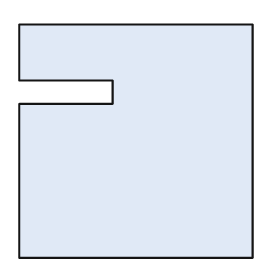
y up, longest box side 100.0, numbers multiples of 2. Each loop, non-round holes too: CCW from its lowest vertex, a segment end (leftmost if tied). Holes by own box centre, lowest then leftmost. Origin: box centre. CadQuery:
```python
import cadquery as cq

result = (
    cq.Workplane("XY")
    .moveTo(-50.0, -50.0)
    .lineTo(50.0, -50.0)
    .lineTo(50.0, 50.0)
    .lineTo(-50.0, 50.0)
    .lineTo(-50.0, 26.0)
    .lineTo(-10.0, 26.0)
    .lineTo(-10.0, 16.0)
    .lineTo(-50.0, 16.0)
    .close()
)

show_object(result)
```